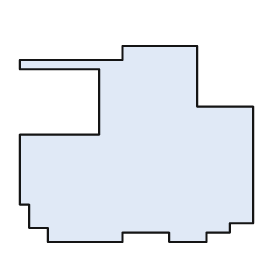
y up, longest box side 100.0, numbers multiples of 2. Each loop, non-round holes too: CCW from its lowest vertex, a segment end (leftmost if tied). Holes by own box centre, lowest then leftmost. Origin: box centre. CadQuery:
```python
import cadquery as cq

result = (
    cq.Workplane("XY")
    .moveTo(-38.0, -42.0)
    .lineTo(-6.0, -42.0)
    .lineTo(-6.0, -38.0)
    .lineTo(14.0, -38.0)
    .lineTo(14.0, -42.0)
    .lineTo(30.0, -42.0)
    .lineTo(30.0, -38.0)
    .lineTo(40.0, -38.0)
    .lineTo(40.0, -34.0)
    .lineTo(50.0, -34.0)
    .lineTo(50.0, 16.0)
    .lineTo(26.0, 16.0)
    .lineTo(26.0, 42.0)
    .lineTo(-6.0, 42.0)
    .lineTo(-6.0, 36.0)
    .lineTo(-50.0, 36.0)
    .lineTo(-50.0, 32.0)
    .lineTo(-16.0, 32.0)
    .lineTo(-16.0, 4.0)
    .lineTo(-50.0, 4.0)
    .lineTo(-50.0, -26.0)
    .lineTo(-46.0, -26.0)
    .lineTo(-46.0, -36.0)
    .lineTo(-38.0, -36.0)
    .close()
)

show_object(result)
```